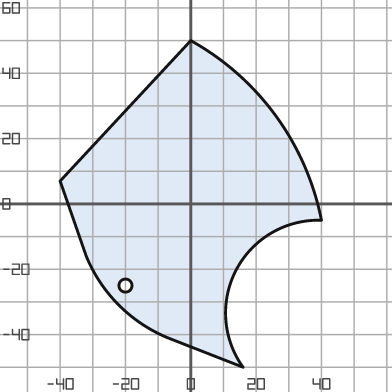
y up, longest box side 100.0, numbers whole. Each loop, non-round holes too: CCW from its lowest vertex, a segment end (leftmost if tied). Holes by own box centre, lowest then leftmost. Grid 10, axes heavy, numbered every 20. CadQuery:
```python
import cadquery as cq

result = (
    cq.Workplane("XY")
    .moveTo(16.0, -50.0)
    .threePointArc((14.0, -20.0), (40.0, -5.0))
    .threePointArc((26.0, 27.0), (0.0, 50.0))
    .lineTo(-40.0, 7.0)
    .lineTo(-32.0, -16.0)
    .threePointArc((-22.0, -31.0), (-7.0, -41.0))
    .close()
    .moveTo(-20.0, -25.0)
    .circle(2.0)
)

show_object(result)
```